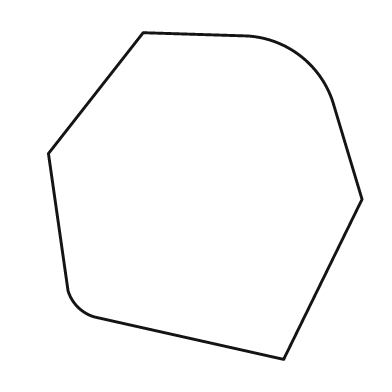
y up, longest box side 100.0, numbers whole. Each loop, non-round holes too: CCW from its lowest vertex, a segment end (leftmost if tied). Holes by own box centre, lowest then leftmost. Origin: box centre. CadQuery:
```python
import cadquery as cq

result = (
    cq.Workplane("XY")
    .moveTo(24.0, -50.0)
    .lineTo(48.0, -1.0)
    .lineTo(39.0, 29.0)
    .threePointArc((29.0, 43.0), (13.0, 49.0))
    .lineTo(-19.0, 50.0)
    .lineTo(-48.0, 13.0)
    .lineTo(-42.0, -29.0)
    .threePointArc((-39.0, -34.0), (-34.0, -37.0))
    .close()
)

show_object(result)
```